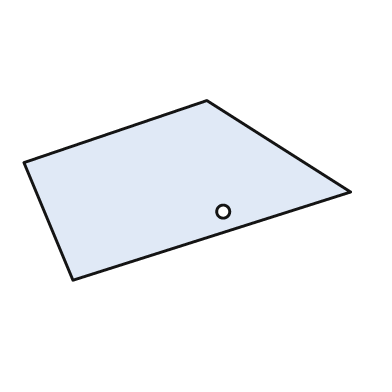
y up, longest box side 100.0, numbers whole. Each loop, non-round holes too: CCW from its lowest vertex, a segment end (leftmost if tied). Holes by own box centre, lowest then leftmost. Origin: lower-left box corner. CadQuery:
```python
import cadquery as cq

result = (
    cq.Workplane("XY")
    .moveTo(15.0, 0.0)
    .lineTo(100.0, 27.0)
    .lineTo(56.0, 55.0)
    .lineTo(0.0, 36.0)
    .close()
    .moveTo(61.0, 21.0)
    .circle(2.0)
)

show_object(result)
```